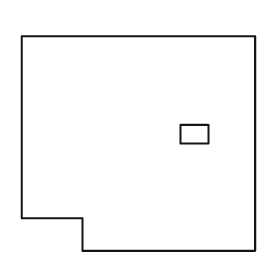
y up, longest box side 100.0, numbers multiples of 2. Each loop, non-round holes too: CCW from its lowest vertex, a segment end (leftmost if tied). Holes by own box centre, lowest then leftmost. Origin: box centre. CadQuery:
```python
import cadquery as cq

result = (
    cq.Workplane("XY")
    .moveTo(-24.0, -46.0)
    .lineTo(50.0, -46.0)
    .lineTo(50.0, 46.0)
    .lineTo(-50.0, 46.0)
    .lineTo(-50.0, -32.0)
    .lineTo(-24.0, -32.0)
    .close()
    .moveTo(18.0, 0.0)
    .lineTo(30.0, 0.0)
    .lineTo(30.0, 8.0)
    .lineTo(18.0, 8.0)
    .close()
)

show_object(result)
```